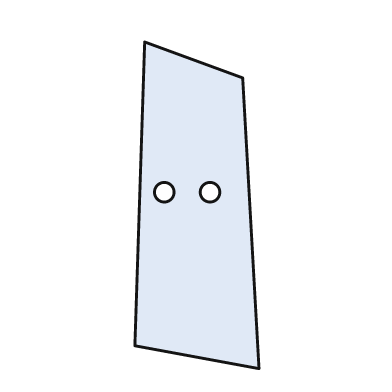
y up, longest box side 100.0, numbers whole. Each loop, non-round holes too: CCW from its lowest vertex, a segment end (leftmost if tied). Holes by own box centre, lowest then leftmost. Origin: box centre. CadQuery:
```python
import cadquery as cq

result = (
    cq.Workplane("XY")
    .moveTo(19.0, -50.0)
    .lineTo(14.0, 39.0)
    .lineTo(-16.0, 50.0)
    .lineTo(-19.0, -43.0)
    .close()
    .moveTo(-10.0, 4.0)
    .circle(3.0)
    .moveTo(4.0, 4.0)
    .circle(3.0)
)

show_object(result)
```